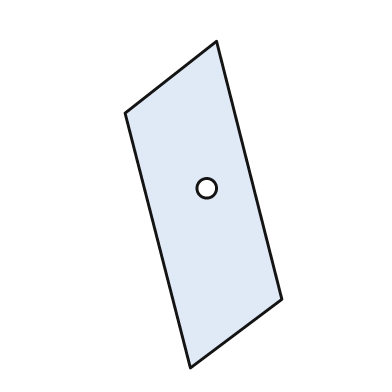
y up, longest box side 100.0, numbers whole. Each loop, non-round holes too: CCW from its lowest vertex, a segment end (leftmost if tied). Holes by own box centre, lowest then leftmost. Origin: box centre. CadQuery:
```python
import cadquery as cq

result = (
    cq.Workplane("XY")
    .moveTo(-4.0, -50.0)
    .lineTo(24.0, -29.0)
    .lineTo(4.0, 50.0)
    .lineTo(-24.0, 28.0)
    .close()
    .moveTo(1.0, 5.0)
    .circle(3.0)
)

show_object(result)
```